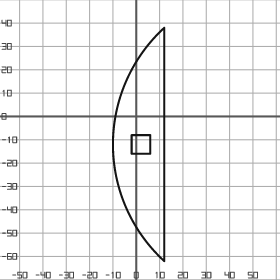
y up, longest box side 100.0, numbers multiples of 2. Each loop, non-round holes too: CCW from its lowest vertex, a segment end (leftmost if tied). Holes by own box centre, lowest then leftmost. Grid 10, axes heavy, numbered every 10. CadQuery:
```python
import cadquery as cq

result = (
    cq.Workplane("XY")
    .moveTo(12.0, -62.0)
    .lineTo(12.0, 38.0)
    .threePointArc((-10.0, -12.0), (12.0, -62.0))
    .close()
    .moveTo(-2.0, -16.0)
    .lineTo(6.0, -16.0)
    .lineTo(6.0, -8.0)
    .lineTo(-2.0, -8.0)
    .close()
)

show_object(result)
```